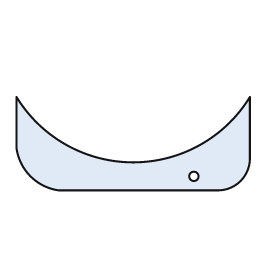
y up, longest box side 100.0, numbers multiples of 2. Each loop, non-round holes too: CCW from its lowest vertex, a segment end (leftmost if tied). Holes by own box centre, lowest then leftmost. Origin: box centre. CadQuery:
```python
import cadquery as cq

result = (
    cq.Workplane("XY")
    .moveTo(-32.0, -20.0)
    .lineTo(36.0, -20.0)
    .threePointArc((46.0, -16.0), (50.0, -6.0))
    .lineTo(50.0, 20.0)
    .threePointArc((0.0, -8.0), (-50.0, 20.0))
    .lineTo(-50.0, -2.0)
    .threePointArc((-44.0, -14.0), (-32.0, -20.0))
    .close()
    .moveTo(26.0, -14.0)
    .circle(2.0)
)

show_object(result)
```